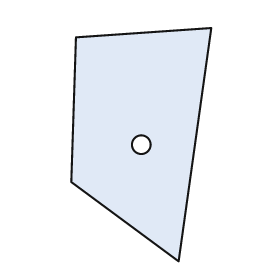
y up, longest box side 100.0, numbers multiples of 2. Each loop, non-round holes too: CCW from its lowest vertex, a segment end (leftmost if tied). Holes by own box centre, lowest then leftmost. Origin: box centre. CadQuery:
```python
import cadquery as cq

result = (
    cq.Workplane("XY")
    .moveTo(16.0, -50.0)
    .lineTo(30.0, 50.0)
    .lineTo(-28.0, 46.0)
    .lineTo(-30.0, -16.0)
    .close()
    .moveTo(0.0, 0.0)
    .circle(4.0)
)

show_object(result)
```